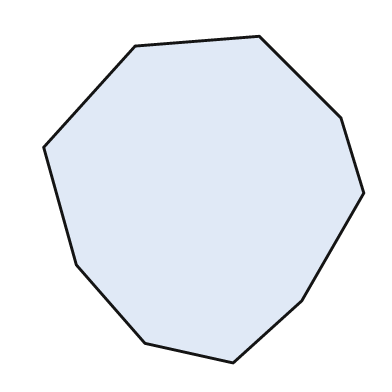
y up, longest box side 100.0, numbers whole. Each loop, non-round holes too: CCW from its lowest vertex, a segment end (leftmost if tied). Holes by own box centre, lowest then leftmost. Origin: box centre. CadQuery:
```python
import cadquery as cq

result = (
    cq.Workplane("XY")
    .moveTo(9.0, -50.0)
    .lineTo(30.0, -31.0)
    .lineTo(49.0, 2.0)
    .lineTo(42.0, 25.0)
    .lineTo(17.0, 50.0)
    .lineTo(-21.0, 47.0)
    .lineTo(-49.0, 16.0)
    .lineTo(-39.0, -20.0)
    .lineTo(-18.0, -44.0)
    .close()
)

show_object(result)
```